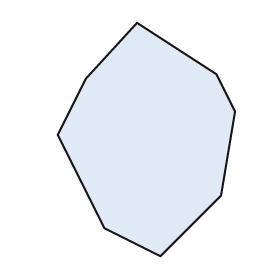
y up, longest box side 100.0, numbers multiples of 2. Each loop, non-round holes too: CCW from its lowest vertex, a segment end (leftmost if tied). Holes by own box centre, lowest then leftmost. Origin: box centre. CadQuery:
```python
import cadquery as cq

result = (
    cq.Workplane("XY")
    .moveTo(6.0, -50.0)
    .lineTo(32.0, -24.0)
    .lineTo(38.0, 12.0)
    .lineTo(30.0, 28.0)
    .lineTo(-4.0, 50.0)
    .lineTo(-26.0, 26.0)
    .lineTo(-38.0, 2.0)
    .lineTo(-18.0, -38.0)
    .close()
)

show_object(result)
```